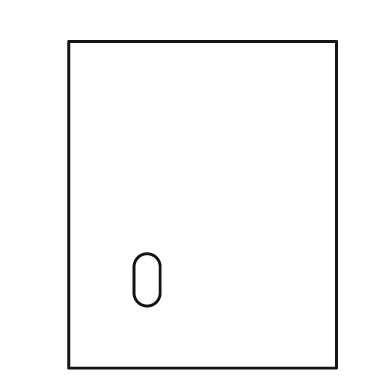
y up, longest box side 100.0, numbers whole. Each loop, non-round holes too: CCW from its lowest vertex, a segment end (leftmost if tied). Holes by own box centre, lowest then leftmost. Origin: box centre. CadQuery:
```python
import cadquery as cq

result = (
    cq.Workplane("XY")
    .moveTo(-41.0, -50.0)
    .lineTo(41.0, -50.0)
    .lineTo(41.0, 50.0)
    .lineTo(-41.0, 50.0)
    .close()
    .moveTo(-21.0, -27.0)
    .threePointArc((-17.0, -31.0), (-13.0, -27.0))
    .lineTo(-13.0, -19.0)
    .threePointArc((-17.0, -15.0), (-21.0, -19.0))
    .close()
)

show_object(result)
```